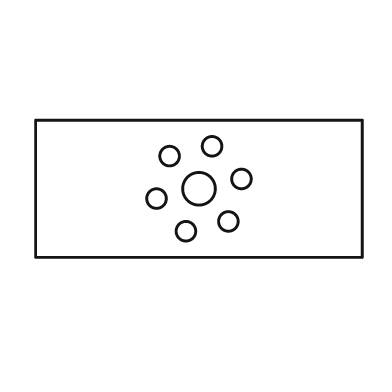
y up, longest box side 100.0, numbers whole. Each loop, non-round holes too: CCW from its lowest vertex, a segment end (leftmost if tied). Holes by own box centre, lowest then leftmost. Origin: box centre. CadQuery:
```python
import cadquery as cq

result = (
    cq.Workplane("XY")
    .moveTo(-50.0, -21.0)
    .lineTo(50.0, -21.0)
    .lineTo(50.0, 21.0)
    .lineTo(-50.0, 21.0)
    .close()
    .moveTo(-4.0, -13.0)
    .circle(3.0)
    .moveTo(9.0, -10.0)
    .circle(3.0)
    .moveTo(-13.0, -3.0)
    .circle(3.0)
    .moveTo(0.0, 0.0)
    .circle(5.0)
    .moveTo(13.0, 3.0)
    .circle(3.0)
    .moveTo(-9.0, 10.0)
    .circle(3.0)
    .moveTo(4.0, 13.0)
    .circle(3.0)
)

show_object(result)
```